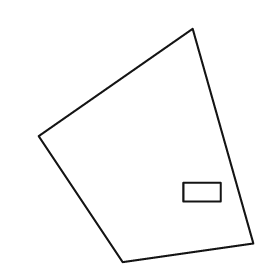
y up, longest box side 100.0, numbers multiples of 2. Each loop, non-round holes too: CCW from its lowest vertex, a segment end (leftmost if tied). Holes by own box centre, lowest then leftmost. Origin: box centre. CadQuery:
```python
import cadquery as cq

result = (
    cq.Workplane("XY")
    .moveTo(-10.0, -50.0)
    .lineTo(46.0, -42.0)
    .lineTo(20.0, 50.0)
    .lineTo(-46.0, 4.0)
    .close()
    .moveTo(16.0, -24.0)
    .lineTo(32.0, -24.0)
    .lineTo(32.0, -16.0)
    .lineTo(16.0, -16.0)
    .close()
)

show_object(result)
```